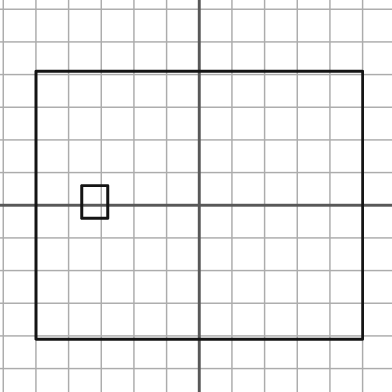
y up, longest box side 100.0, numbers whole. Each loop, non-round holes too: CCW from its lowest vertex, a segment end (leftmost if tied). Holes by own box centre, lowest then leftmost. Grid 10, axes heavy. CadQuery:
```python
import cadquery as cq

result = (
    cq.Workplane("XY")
    .moveTo(-50.0, -41.0)
    .lineTo(50.0, -41.0)
    .lineTo(50.0, 41.0)
    .lineTo(-50.0, 41.0)
    .close()
    .moveTo(-36.0, -4.0)
    .lineTo(-28.0, -4.0)
    .lineTo(-28.0, 6.0)
    .lineTo(-36.0, 6.0)
    .close()
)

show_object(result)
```